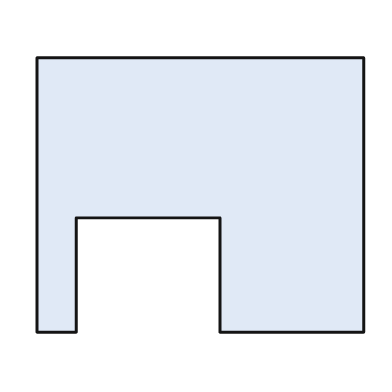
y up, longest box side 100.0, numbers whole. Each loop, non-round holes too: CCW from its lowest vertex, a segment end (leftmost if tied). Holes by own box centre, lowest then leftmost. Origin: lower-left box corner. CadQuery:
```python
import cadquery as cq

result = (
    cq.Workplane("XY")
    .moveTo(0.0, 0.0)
    .lineTo(12.0, 0.0)
    .lineTo(12.0, 35.0)
    .lineTo(56.0, 35.0)
    .lineTo(56.0, 0.0)
    .lineTo(100.0, 0.0)
    .lineTo(100.0, 84.0)
    .lineTo(0.0, 84.0)
    .close()
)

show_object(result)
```